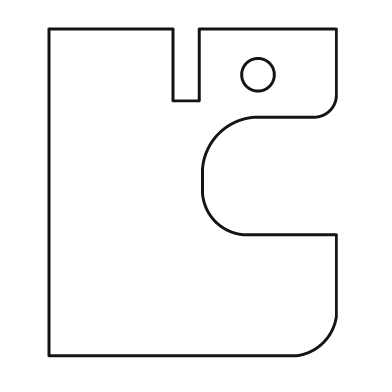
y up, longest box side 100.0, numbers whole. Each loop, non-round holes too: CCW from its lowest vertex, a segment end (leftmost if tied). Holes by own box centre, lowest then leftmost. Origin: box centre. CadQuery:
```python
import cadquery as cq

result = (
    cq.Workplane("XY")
    .moveTo(-44.0, -50.0)
    .lineTo(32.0, -50.0)
    .threePointArc((40.0, -46.0), (44.0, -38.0))
    .lineTo(44.0, -13.0)
    .lineTo(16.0, -13.0)
    .threePointArc((7.0, -9.0), (3.0, 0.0))
    .lineTo(3.0, 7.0)
    .threePointArc((8.0, 18.0), (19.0, 23.0))
    .lineTo(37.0, 23.0)
    .threePointArc((42.0, 25.0), (44.0, 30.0))
    .lineTo(44.0, 50.0)
    .lineTo(2.0, 50.0)
    .lineTo(2.0, 28.0)
    .lineTo(-6.0, 28.0)
    .lineTo(-6.0, 50.0)
    .lineTo(-44.0, 50.0)
    .close()
    .moveTo(20.0, 36.0)
    .circle(5.0)
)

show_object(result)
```